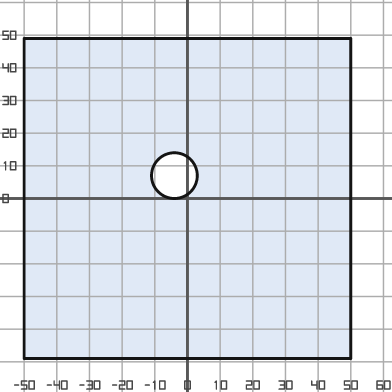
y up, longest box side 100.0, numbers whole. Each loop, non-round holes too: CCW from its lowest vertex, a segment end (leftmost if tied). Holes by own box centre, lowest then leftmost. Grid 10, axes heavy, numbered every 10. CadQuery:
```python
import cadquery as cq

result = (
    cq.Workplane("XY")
    .moveTo(-50.0, -49.0)
    .lineTo(50.0, -49.0)
    .lineTo(50.0, 49.0)
    .lineTo(-50.0, 49.0)
    .close()
    .moveTo(-4.0, 7.0)
    .circle(7.0)
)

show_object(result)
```